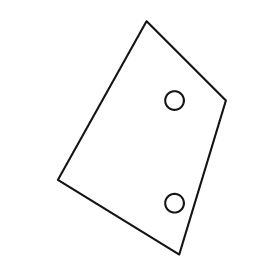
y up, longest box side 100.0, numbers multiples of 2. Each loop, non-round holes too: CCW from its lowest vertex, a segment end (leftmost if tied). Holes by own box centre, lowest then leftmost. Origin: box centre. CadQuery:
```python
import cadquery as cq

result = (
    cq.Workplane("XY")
    .moveTo(16.0, -50.0)
    .lineTo(36.0, 16.0)
    .lineTo(2.0, 50.0)
    .lineTo(-36.0, -18.0)
    .close()
    .moveTo(14.0, -28.0)
    .circle(4.0)
    .moveTo(14.0, 16.0)
    .circle(4.0)
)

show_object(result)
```